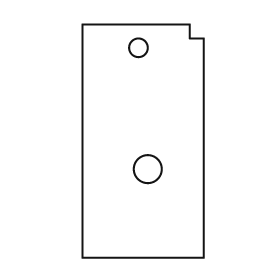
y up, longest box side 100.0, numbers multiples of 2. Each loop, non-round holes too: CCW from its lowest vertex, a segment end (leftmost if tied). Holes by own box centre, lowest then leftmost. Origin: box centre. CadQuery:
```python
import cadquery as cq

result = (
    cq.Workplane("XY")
    .moveTo(-26.0, -50.0)
    .lineTo(26.0, -50.0)
    .lineTo(26.0, 44.0)
    .lineTo(20.0, 44.0)
    .lineTo(20.0, 50.0)
    .lineTo(-26.0, 50.0)
    .close()
    .moveTo(2.0, -12.0)
    .circle(6.0)
    .moveTo(-2.0, 40.0)
    .circle(4.0)
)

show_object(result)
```